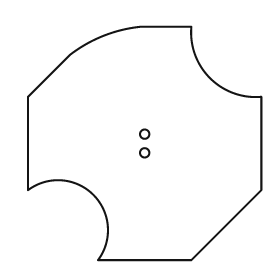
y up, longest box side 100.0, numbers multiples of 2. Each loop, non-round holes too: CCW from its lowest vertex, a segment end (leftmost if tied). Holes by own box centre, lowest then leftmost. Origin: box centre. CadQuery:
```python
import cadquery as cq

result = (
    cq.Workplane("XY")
    .moveTo(-20.0, -50.0)
    .lineTo(20.0, -50.0)
    .lineTo(50.0, -20.0)
    .lineTo(50.0, 20.0)
    .threePointArc((28.0, 28.0), (20.0, 50.0))
    .lineTo(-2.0, 50.0)
    .threePointArc((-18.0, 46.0), (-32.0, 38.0))
    .lineTo(-50.0, 20.0)
    .lineTo(-50.0, -20.0)
    .threePointArc((-22.0, -22.0), (-20.0, -50.0))
    .close()
    .moveTo(0.0, -4.0)
    .circle(2.0)
    .moveTo(0.0, 4.0)
    .circle(2.0)
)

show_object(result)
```